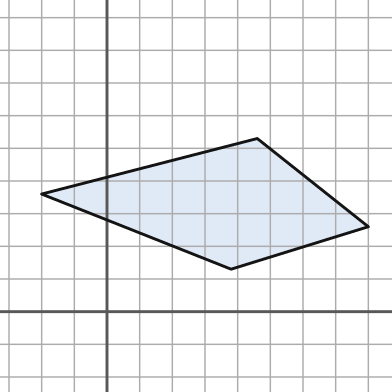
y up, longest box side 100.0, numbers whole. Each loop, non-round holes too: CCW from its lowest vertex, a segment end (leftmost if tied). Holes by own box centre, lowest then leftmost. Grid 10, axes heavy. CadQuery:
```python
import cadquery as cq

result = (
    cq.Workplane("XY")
    .moveTo(38.0, 13.0)
    .lineTo(80.0, 26.0)
    .lineTo(46.0, 53.0)
    .lineTo(-20.0, 36.0)
    .close()
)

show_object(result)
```